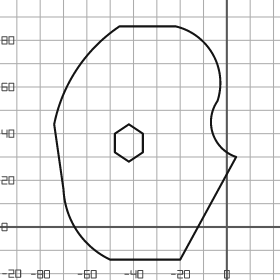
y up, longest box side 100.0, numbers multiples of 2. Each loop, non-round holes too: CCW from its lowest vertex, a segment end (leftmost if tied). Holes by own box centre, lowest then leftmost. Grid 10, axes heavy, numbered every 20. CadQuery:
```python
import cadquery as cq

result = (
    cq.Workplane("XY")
    .moveTo(-50.0, -14.0)
    .lineTo(-20.0, -14.0)
    .lineTo(4.0, 30.0)
    .threePointArc((-6.0, 40.0), (-4.0, 54.0))
    .threePointArc((-6.0, 74.0), (-22.0, 86.0))
    .lineTo(-46.0, 86.0)
    .threePointArc((-64.0, 68.0), (-74.0, 44.0))
    .lineTo(-70.0, 16.0)
    .threePointArc((-64.0, -2.0), (-50.0, -14.0))
    .close()
    .moveTo(-42.0, 28.0)
    .lineTo(-36.0, 32.0)
    .lineTo(-36.0, 40.0)
    .lineTo(-42.0, 44.0)
    .lineTo(-48.0, 40.0)
    .lineTo(-48.0, 32.0)
    .close()
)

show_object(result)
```